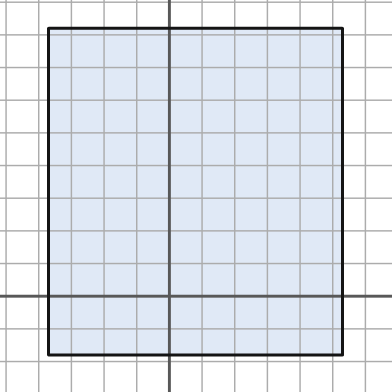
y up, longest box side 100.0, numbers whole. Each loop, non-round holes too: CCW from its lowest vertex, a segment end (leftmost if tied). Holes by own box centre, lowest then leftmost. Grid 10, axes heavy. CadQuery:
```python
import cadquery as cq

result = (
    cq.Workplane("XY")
    .moveTo(-37.0, -18.0)
    .lineTo(53.0, -18.0)
    .lineTo(53.0, 82.0)
    .lineTo(-37.0, 82.0)
    .close()
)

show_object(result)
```